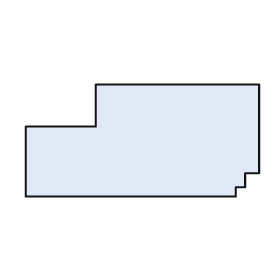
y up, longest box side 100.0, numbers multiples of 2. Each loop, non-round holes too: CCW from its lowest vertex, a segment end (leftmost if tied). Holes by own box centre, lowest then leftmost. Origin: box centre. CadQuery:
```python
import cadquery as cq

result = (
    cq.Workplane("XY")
    .moveTo(-50.0, -24.0)
    .lineTo(40.0, -24.0)
    .lineTo(40.0, -20.0)
    .lineTo(44.0, -20.0)
    .lineTo(44.0, -14.0)
    .lineTo(50.0, -14.0)
    .lineTo(50.0, 24.0)
    .lineTo(-20.0, 24.0)
    .lineTo(-20.0, 6.0)
    .lineTo(-50.0, 6.0)
    .close()
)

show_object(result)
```